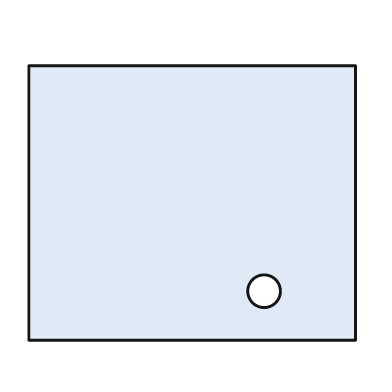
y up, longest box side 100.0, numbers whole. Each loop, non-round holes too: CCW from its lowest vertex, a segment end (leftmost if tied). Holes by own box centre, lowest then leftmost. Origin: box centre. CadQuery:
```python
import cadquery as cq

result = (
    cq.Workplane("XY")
    .moveTo(-50.0, -42.0)
    .lineTo(50.0, -42.0)
    .lineTo(50.0, 42.0)
    .lineTo(-50.0, 42.0)
    .close()
    .moveTo(22.0, -27.0)
    .circle(5.0)
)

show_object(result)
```